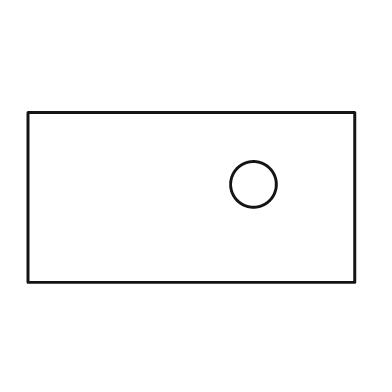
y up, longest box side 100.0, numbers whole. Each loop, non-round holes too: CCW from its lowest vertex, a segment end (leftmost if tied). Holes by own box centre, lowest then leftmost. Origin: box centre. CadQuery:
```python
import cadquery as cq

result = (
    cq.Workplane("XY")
    .moveTo(-50.0, -26.0)
    .lineTo(50.0, -26.0)
    .lineTo(50.0, 26.0)
    .lineTo(-50.0, 26.0)
    .close()
    .moveTo(19.0, 4.0)
    .circle(7.0)
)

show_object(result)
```